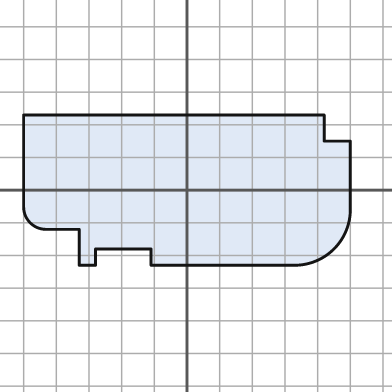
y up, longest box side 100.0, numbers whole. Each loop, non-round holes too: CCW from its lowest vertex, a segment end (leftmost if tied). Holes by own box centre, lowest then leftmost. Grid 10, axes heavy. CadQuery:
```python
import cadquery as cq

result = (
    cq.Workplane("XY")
    .moveTo(-33.0, -23.0)
    .lineTo(-28.0, -23.0)
    .lineTo(-28.0, -18.0)
    .lineTo(-11.0, -18.0)
    .lineTo(-11.0, -23.0)
    .lineTo(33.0, -23.0)
    .threePointArc((45.0, -18.0), (50.0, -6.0))
    .lineTo(50.0, 15.0)
    .lineTo(42.0, 15.0)
    .lineTo(42.0, 23.0)
    .lineTo(-50.0, 23.0)
    .lineTo(-50.0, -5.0)
    .threePointArc((-48.0, -10.0), (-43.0, -12.0))
    .lineTo(-33.0, -12.0)
    .close()
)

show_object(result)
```